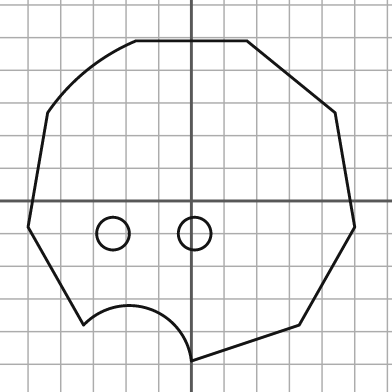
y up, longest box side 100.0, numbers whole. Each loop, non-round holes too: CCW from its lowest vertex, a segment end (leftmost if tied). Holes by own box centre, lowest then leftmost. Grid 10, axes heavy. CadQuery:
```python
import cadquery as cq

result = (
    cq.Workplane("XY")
    .moveTo(0.0, -49.0)
    .lineTo(33.0, -38.0)
    .lineTo(50.0, -8.0)
    .lineTo(44.0, 27.0)
    .lineTo(17.0, 49.0)
    .lineTo(-17.0, 49.0)
    .threePointArc((-32.0, 40.0), (-44.0, 27.0))
    .lineTo(-50.0, -8.0)
    .lineTo(-33.0, -38.0)
    .threePointArc((-13.0, -33.0), (0.0, -49.0))
    .close()
    .moveTo(-24.0, -10.0)
    .circle(5.0)
    .moveTo(1.0, -10.0)
    .circle(5.0)
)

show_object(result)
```